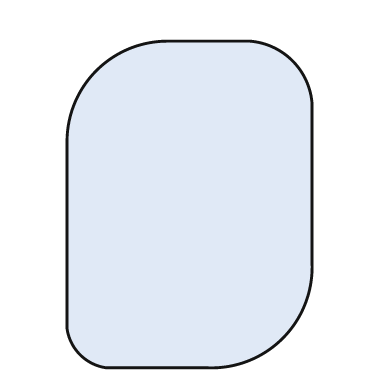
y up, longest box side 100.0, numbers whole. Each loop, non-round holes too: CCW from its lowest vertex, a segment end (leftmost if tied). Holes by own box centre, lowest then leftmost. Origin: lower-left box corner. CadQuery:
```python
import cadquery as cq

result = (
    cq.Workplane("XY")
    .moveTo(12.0, 0.0)
    .lineTo(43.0, 0.0)
    .threePointArc((66.0, 9.0), (75.0, 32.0))
    .lineTo(75.0, 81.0)
    .threePointArc((69.0, 94.0), (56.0, 100.0))
    .lineTo(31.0, 100.0)
    .threePointArc((9.0, 91.0), (0.0, 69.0))
    .lineTo(0.0, 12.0)
    .threePointArc((4.0, 4.0), (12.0, 0.0))
    .close()
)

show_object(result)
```